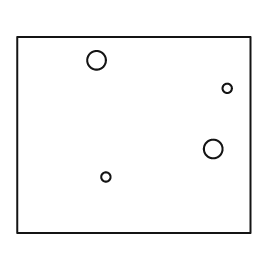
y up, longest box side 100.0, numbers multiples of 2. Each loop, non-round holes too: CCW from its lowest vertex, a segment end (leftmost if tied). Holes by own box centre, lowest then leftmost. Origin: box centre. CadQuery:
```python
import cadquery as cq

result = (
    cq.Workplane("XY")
    .moveTo(-50.0, -42.0)
    .lineTo(50.0, -42.0)
    .lineTo(50.0, 42.0)
    .lineTo(-50.0, 42.0)
    .close()
    .moveTo(-12.0, -18.0)
    .circle(2.0)
    .moveTo(34.0, -6.0)
    .circle(4.0)
    .moveTo(40.0, 20.0)
    .circle(2.0)
    .moveTo(-16.0, 32.0)
    .circle(4.0)
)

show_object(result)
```